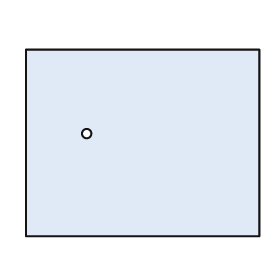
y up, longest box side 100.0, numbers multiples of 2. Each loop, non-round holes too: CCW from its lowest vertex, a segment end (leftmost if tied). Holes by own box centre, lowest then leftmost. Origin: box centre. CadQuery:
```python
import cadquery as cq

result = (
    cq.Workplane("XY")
    .moveTo(-50.0, -40.0)
    .lineTo(50.0, -40.0)
    .lineTo(50.0, 40.0)
    .lineTo(-50.0, 40.0)
    .close()
    .moveTo(-24.0, 4.0)
    .circle(2.0)
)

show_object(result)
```